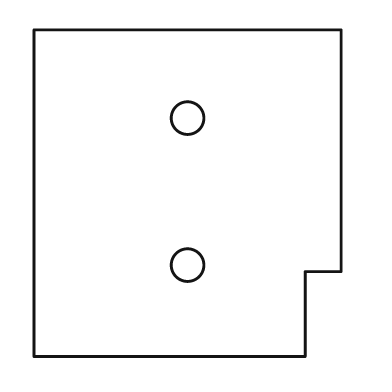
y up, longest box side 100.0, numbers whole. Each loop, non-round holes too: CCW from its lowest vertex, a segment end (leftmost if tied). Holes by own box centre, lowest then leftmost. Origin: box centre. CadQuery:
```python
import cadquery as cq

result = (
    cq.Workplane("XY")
    .moveTo(-47.0, -50.0)
    .lineTo(36.0, -50.0)
    .lineTo(36.0, -24.0)
    .lineTo(47.0, -24.0)
    .lineTo(47.0, 50.0)
    .lineTo(-47.0, 50.0)
    .close()
    .moveTo(0.0, -22.0)
    .circle(5.0)
    .moveTo(0.0, 23.0)
    .circle(5.0)
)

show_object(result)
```